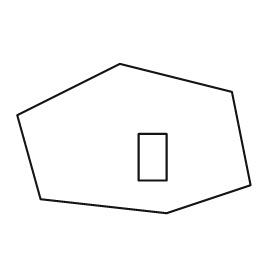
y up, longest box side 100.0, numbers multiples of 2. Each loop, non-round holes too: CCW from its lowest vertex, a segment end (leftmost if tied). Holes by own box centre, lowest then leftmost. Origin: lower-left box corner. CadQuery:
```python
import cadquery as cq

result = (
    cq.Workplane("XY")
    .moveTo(64.0, 0.0)
    .lineTo(100.0, 12.0)
    .lineTo(92.0, 52.0)
    .lineTo(44.0, 64.0)
    .lineTo(0.0, 42.0)
    .lineTo(10.0, 6.0)
    .close()
    .moveTo(52.0, 14.0)
    .lineTo(64.0, 14.0)
    .lineTo(64.0, 34.0)
    .lineTo(52.0, 34.0)
    .close()
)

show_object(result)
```